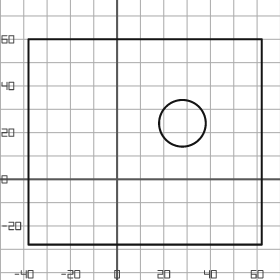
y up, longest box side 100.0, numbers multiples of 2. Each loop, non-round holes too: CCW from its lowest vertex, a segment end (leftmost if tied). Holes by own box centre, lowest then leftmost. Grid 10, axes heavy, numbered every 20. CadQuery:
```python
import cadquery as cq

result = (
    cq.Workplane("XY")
    .moveTo(-38.0, -28.0)
    .lineTo(62.0, -28.0)
    .lineTo(62.0, 60.0)
    .lineTo(-38.0, 60.0)
    .close()
    .moveTo(28.0, 24.0)
    .circle(10.0)
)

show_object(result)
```